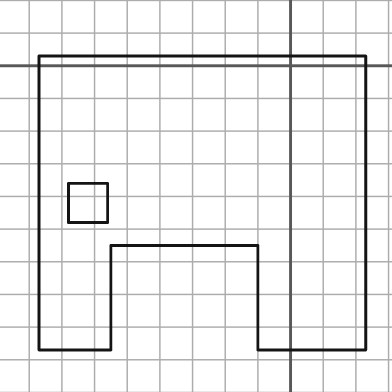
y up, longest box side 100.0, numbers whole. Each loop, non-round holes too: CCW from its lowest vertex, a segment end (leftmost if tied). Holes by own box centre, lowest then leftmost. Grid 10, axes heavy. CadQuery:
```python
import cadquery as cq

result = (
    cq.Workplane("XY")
    .moveTo(-77.0, -87.0)
    .lineTo(-55.0, -87.0)
    .lineTo(-55.0, -55.0)
    .lineTo(-10.0, -55.0)
    .lineTo(-10.0, -87.0)
    .lineTo(23.0, -87.0)
    .lineTo(23.0, 3.0)
    .lineTo(-77.0, 3.0)
    .close()
    .moveTo(-68.0, -48.0)
    .lineTo(-56.0, -48.0)
    .lineTo(-56.0, -36.0)
    .lineTo(-68.0, -36.0)
    .close()
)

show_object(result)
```